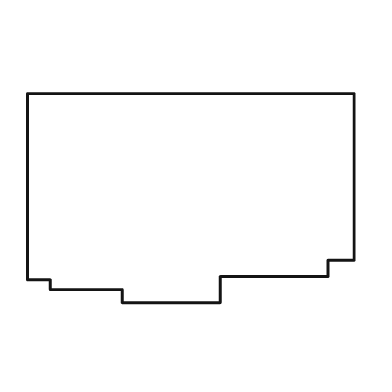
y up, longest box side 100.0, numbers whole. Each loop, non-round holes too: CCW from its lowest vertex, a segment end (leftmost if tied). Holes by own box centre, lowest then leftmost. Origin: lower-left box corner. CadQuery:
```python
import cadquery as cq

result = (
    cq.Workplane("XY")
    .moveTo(29.0, 0.0)
    .lineTo(59.0, 0.0)
    .lineTo(59.0, 8.0)
    .lineTo(92.0, 8.0)
    .lineTo(92.0, 13.0)
    .lineTo(100.0, 13.0)
    .lineTo(100.0, 64.0)
    .lineTo(0.0, 64.0)
    .lineTo(0.0, 7.0)
    .lineTo(7.0, 7.0)
    .lineTo(7.0, 4.0)
    .lineTo(29.0, 4.0)
    .close()
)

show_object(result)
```